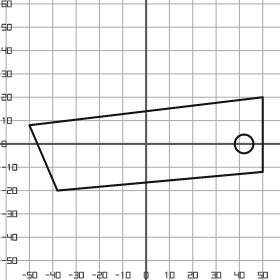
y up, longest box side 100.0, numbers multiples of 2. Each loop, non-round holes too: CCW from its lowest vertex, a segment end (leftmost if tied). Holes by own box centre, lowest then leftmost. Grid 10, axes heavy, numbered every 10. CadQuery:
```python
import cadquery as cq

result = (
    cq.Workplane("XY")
    .moveTo(-38.0, -20.0)
    .lineTo(50.0, -12.0)
    .lineTo(50.0, 20.0)
    .lineTo(-50.0, 8.0)
    .close()
    .moveTo(42.0, 0.0)
    .circle(4.0)
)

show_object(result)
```